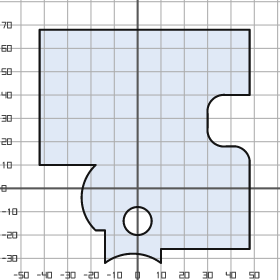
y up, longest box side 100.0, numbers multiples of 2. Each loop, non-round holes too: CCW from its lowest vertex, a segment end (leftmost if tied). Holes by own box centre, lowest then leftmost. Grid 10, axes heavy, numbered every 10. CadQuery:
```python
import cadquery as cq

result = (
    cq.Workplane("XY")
    .moveTo(-14.0, -32.0)
    .threePointArc((-2.0, -28.0), (10.0, -32.0))
    .lineTo(10.0, -26.0)
    .lineTo(48.0, -26.0)
    .lineTo(48.0, 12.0)
    .threePointArc((46.0, 16.0), (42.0, 18.0))
    .lineTo(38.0, 18.0)
    .threePointArc((32.0, 20.0), (30.0, 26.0))
    .lineTo(30.0, 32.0)
    .threePointArc((32.0, 38.0), (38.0, 40.0))
    .lineTo(48.0, 40.0)
    .lineTo(48.0, 68.0)
    .lineTo(-42.0, 68.0)
    .lineTo(-42.0, 10.0)
    .lineTo(-18.0, 10.0)
    .threePointArc((-24.0, -4.0), (-18.0, -18.0))
    .lineTo(-14.0, -18.0)
    .close()
    .moveTo(0.0, -14.0)
    .circle(6.0)
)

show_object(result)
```